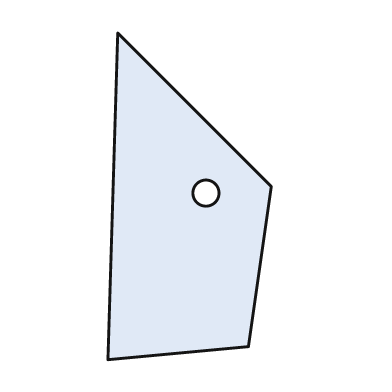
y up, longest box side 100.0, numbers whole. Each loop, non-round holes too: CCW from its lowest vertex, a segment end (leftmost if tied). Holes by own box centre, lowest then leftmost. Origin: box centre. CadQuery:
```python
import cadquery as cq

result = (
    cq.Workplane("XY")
    .moveTo(-25.0, -50.0)
    .lineTo(18.0, -46.0)
    .lineTo(25.0, 3.0)
    .lineTo(-22.0, 50.0)
    .close()
    .moveTo(5.0, 1.0)
    .circle(4.0)
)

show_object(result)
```